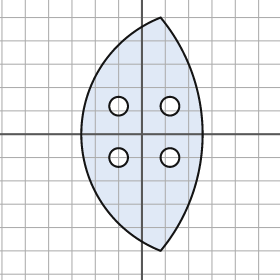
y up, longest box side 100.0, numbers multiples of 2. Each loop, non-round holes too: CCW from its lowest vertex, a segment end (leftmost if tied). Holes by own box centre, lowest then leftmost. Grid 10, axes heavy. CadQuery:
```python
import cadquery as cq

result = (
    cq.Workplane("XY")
    .moveTo(8.0, -50.0)
    .threePointArc((26.0, 0.0), (8.0, 50.0))
    .threePointArc((-26.0, 0.0), (8.0, -50.0))
    .close()
    .moveTo(-10.0, -10.0)
    .circle(4.0)
    .moveTo(12.0, -10.0)
    .circle(4.0)
    .moveTo(-10.0, 12.0)
    .circle(4.0)
    .moveTo(12.0, 12.0)
    .circle(4.0)
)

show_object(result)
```